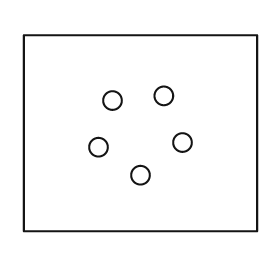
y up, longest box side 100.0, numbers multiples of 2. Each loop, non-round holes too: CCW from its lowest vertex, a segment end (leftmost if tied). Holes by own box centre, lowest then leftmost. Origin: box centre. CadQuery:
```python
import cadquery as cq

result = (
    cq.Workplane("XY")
    .moveTo(-50.0, -42.0)
    .lineTo(50.0, -42.0)
    .lineTo(50.0, 42.0)
    .lineTo(-50.0, 42.0)
    .close()
    .moveTo(0.0, -18.0)
    .circle(4.0)
    .moveTo(-18.0, -6.0)
    .circle(4.0)
    .moveTo(18.0, -4.0)
    .circle(4.0)
    .moveTo(-12.0, 14.0)
    .circle(4.0)
    .moveTo(10.0, 16.0)
    .circle(4.0)
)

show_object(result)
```